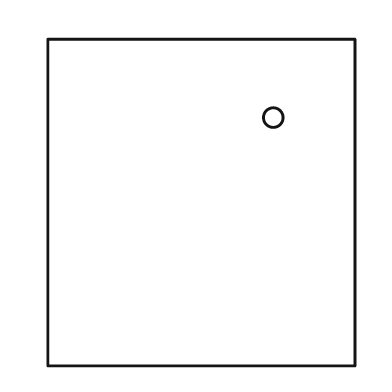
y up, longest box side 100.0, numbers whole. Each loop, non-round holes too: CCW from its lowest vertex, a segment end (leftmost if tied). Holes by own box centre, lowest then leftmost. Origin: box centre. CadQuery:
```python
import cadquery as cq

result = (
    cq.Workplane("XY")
    .moveTo(-47.0, -50.0)
    .lineTo(47.0, -50.0)
    .lineTo(47.0, 50.0)
    .lineTo(-47.0, 50.0)
    .close()
    .moveTo(22.0, 26.0)
    .circle(3.0)
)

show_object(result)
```